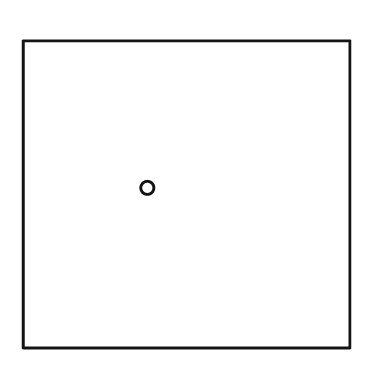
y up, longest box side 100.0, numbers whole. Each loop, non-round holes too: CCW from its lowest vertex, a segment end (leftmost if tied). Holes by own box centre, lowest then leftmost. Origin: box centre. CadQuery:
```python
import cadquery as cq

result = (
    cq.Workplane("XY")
    .moveTo(-50.0, -47.0)
    .lineTo(50.0, -47.0)
    .lineTo(50.0, 47.0)
    .lineTo(-50.0, 47.0)
    .close()
    .moveTo(-12.0, 2.0)
    .circle(2.0)
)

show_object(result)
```